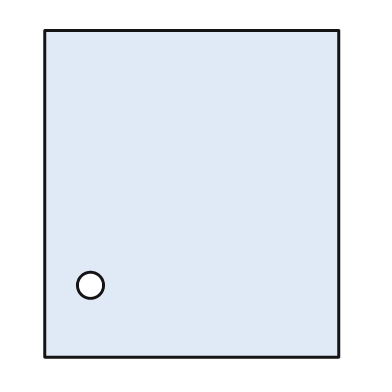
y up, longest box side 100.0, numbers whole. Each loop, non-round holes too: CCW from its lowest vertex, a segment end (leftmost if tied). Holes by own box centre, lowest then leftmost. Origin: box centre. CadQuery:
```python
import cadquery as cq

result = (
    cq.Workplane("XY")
    .moveTo(-45.0, -50.0)
    .lineTo(45.0, -50.0)
    .lineTo(45.0, 50.0)
    .lineTo(-45.0, 50.0)
    .close()
    .moveTo(-31.0, -28.0)
    .circle(4.0)
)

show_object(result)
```